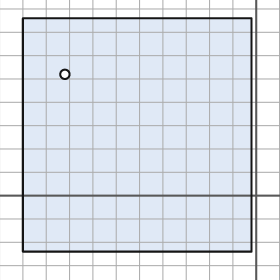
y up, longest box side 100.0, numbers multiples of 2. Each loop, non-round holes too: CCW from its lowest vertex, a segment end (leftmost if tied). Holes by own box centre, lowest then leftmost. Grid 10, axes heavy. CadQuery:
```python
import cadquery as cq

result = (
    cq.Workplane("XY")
    .moveTo(-100.0, -24.0)
    .lineTo(-2.0, -24.0)
    .lineTo(-2.0, 76.0)
    .lineTo(-100.0, 76.0)
    .close()
    .moveTo(-82.0, 52.0)
    .circle(2.0)
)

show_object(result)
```